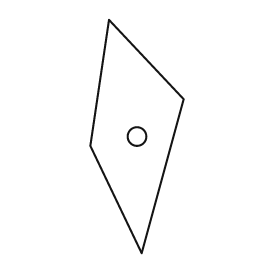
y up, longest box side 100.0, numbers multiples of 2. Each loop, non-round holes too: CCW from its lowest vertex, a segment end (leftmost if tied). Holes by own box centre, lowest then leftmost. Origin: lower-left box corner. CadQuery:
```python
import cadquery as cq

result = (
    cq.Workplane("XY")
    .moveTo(22.0, 0.0)
    .lineTo(40.0, 66.0)
    .lineTo(8.0, 100.0)
    .lineTo(0.0, 46.0)
    .close()
    .moveTo(20.0, 50.0)
    .circle(4.0)
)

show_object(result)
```